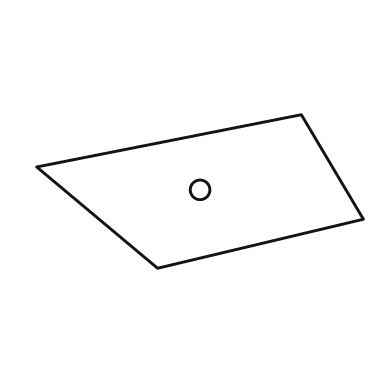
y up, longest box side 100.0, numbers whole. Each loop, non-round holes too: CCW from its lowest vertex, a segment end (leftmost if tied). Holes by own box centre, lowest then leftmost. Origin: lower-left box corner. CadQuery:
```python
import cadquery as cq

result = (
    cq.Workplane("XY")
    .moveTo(37.0, 0.0)
    .lineTo(100.0, 15.0)
    .lineTo(81.0, 47.0)
    .lineTo(0.0, 31.0)
    .close()
    .moveTo(50.0, 24.0)
    .circle(3.0)
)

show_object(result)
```